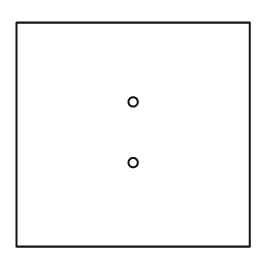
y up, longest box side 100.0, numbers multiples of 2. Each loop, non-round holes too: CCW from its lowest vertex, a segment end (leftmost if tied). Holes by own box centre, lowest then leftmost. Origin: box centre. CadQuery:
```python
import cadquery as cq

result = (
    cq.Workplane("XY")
    .moveTo(-50.0, -48.0)
    .lineTo(50.0, -48.0)
    .lineTo(50.0, 48.0)
    .lineTo(-50.0, 48.0)
    .close()
    .moveTo(0.0, -12.0)
    .circle(2.0)
    .moveTo(0.0, 14.0)
    .circle(2.0)
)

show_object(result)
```